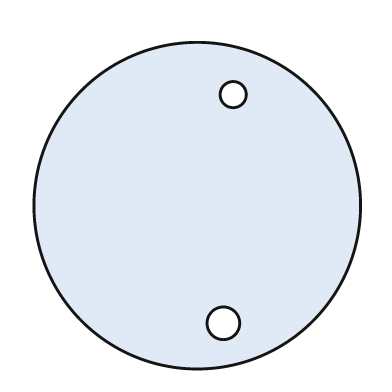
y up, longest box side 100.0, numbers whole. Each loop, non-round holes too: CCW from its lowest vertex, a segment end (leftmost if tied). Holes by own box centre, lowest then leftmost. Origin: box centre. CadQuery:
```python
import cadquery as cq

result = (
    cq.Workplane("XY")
    .moveTo(0.0, 0.0)
    .circle(50.0)
    .moveTo(8.0, -36.0)
    .circle(5.0)
    .moveTo(11.0, 34.0)
    .circle(4.0)
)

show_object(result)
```